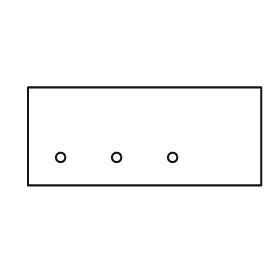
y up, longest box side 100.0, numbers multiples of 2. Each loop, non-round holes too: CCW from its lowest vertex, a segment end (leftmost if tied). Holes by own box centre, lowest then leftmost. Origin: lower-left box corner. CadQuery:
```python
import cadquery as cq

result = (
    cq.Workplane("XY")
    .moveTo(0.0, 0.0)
    .lineTo(100.0, 0.0)
    .lineTo(100.0, 42.0)
    .lineTo(0.0, 42.0)
    .close()
    .moveTo(14.0, 12.0)
    .circle(2.0)
    .moveTo(38.0, 12.0)
    .circle(2.0)
    .moveTo(62.0, 12.0)
    .circle(2.0)
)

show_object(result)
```